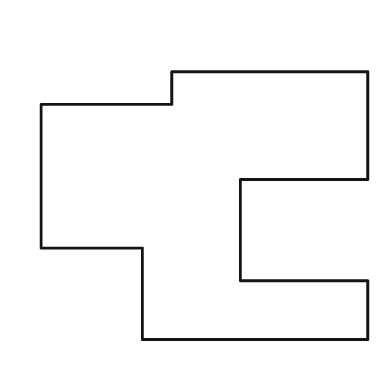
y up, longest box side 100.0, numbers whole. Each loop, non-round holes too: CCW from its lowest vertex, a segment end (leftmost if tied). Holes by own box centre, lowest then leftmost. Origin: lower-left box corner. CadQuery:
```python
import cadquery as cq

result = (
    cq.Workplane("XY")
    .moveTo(31.0, 0.0)
    .lineTo(100.0, 0.0)
    .lineTo(100.0, 18.0)
    .lineTo(61.0, 18.0)
    .lineTo(61.0, 49.0)
    .lineTo(100.0, 49.0)
    .lineTo(100.0, 82.0)
    .lineTo(40.0, 82.0)
    .lineTo(40.0, 72.0)
    .lineTo(0.0, 72.0)
    .lineTo(0.0, 28.0)
    .lineTo(31.0, 28.0)
    .close()
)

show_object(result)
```